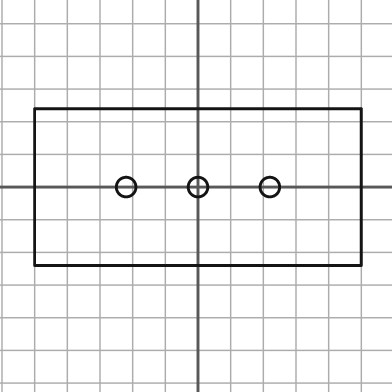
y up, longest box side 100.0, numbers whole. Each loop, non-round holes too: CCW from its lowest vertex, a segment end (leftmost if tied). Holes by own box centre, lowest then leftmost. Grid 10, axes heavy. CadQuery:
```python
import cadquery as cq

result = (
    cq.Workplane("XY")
    .moveTo(-50.0, -24.0)
    .lineTo(50.0, -24.0)
    .lineTo(50.0, 24.0)
    .lineTo(-50.0, 24.0)
    .close()
    .moveTo(-22.0, 0.0)
    .circle(3.0)
    .moveTo(0.0, 0.0)
    .circle(3.0)
    .moveTo(22.0, 0.0)
    .circle(3.0)
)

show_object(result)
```